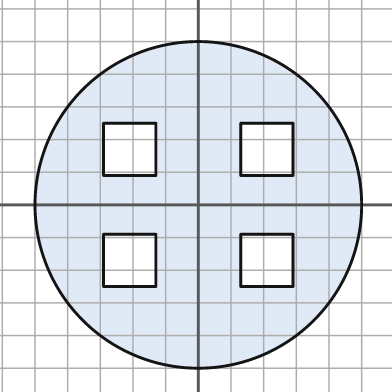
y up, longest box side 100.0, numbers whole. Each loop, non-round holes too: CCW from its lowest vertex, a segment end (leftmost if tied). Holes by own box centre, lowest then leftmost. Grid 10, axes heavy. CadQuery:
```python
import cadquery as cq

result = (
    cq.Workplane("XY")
    .moveTo(0.0, 0.0)
    .circle(50.0)
    .moveTo(-29.0, -25.0)
    .lineTo(-13.0, -25.0)
    .lineTo(-13.0, -9.0)
    .lineTo(-29.0, -9.0)
    .close()
    .moveTo(13.0, -25.0)
    .lineTo(29.0, -25.0)
    .lineTo(29.0, -9.0)
    .lineTo(13.0, -9.0)
    .close()
    .moveTo(-29.0, 9.0)
    .lineTo(-13.0, 9.0)
    .lineTo(-13.0, 25.0)
    .lineTo(-29.0, 25.0)
    .close()
    .moveTo(13.0, 9.0)
    .lineTo(29.0, 9.0)
    .lineTo(29.0, 25.0)
    .lineTo(13.0, 25.0)
    .close()
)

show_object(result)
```